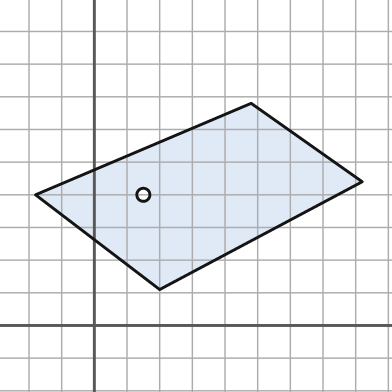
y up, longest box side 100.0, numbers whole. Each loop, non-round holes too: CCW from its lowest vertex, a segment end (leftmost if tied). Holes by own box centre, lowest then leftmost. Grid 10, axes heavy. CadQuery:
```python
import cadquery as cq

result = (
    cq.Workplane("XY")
    .moveTo(20.0, 11.0)
    .lineTo(82.0, 44.0)
    .lineTo(48.0, 68.0)
    .lineTo(-18.0, 40.0)
    .close()
    .moveTo(15.0, 40.0)
    .circle(2.0)
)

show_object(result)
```